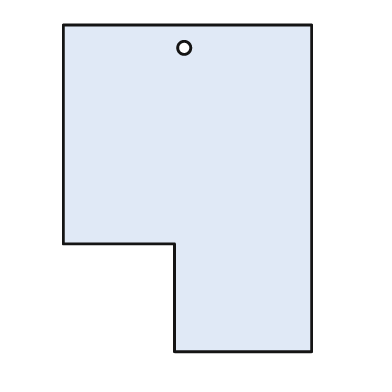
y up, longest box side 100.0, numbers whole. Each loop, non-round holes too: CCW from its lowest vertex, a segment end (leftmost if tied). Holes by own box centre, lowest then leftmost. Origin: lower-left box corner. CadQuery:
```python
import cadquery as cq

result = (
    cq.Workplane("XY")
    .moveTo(34.0, 0.0)
    .lineTo(76.0, 0.0)
    .lineTo(76.0, 100.0)
    .lineTo(0.0, 100.0)
    .lineTo(0.0, 33.0)
    .lineTo(34.0, 33.0)
    .close()
    .moveTo(37.0, 93.0)
    .circle(2.0)
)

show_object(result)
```